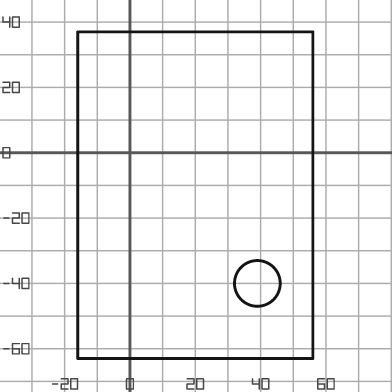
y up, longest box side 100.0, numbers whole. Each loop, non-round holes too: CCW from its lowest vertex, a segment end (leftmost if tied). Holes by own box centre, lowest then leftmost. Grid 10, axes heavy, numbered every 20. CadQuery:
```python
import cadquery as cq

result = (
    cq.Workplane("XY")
    .moveTo(-16.0, -63.0)
    .lineTo(56.0, -63.0)
    .lineTo(56.0, 37.0)
    .lineTo(-16.0, 37.0)
    .close()
    .moveTo(39.0, -40.0)
    .circle(7.0)
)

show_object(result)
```